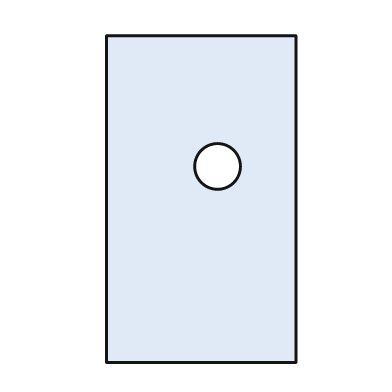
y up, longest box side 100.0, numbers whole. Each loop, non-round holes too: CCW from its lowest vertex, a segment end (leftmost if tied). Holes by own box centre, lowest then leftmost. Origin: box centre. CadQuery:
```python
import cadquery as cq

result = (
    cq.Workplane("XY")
    .moveTo(-29.0, -50.0)
    .lineTo(29.0, -50.0)
    .lineTo(29.0, 50.0)
    .lineTo(-29.0, 50.0)
    .close()
    .moveTo(5.0, 10.0)
    .circle(7.0)
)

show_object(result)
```